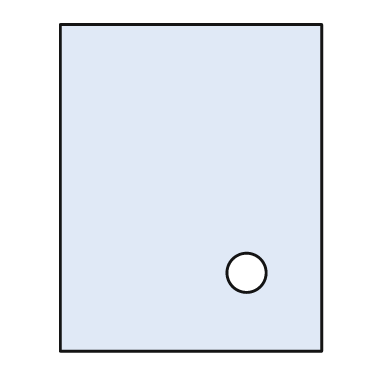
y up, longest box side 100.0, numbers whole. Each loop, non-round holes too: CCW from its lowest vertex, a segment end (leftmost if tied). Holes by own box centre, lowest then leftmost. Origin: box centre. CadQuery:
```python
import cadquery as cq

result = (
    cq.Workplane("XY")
    .moveTo(-40.0, -50.0)
    .lineTo(40.0, -50.0)
    .lineTo(40.0, 50.0)
    .lineTo(-40.0, 50.0)
    .close()
    .moveTo(17.0, -26.0)
    .circle(6.0)
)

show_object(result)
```